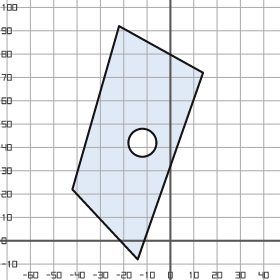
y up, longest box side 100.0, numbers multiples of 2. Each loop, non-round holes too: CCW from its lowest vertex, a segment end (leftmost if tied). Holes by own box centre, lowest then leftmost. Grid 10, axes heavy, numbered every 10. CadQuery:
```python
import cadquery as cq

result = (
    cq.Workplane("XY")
    .moveTo(-14.0, -8.0)
    .lineTo(14.0, 72.0)
    .lineTo(-22.0, 92.0)
    .lineTo(-42.0, 22.0)
    .close()
    .moveTo(-12.0, 42.0)
    .circle(6.0)
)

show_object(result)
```